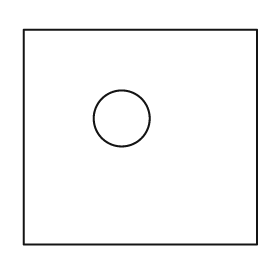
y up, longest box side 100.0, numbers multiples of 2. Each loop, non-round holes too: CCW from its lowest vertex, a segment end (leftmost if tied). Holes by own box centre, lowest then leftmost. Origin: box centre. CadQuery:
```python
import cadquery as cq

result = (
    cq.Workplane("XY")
    .moveTo(-50.0, -46.0)
    .lineTo(50.0, -46.0)
    .lineTo(50.0, 46.0)
    .lineTo(-50.0, 46.0)
    .close()
    .moveTo(-8.0, 8.0)
    .circle(12.0)
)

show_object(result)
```